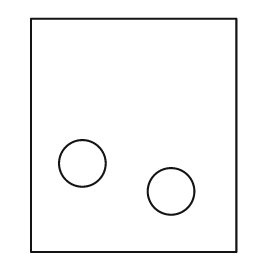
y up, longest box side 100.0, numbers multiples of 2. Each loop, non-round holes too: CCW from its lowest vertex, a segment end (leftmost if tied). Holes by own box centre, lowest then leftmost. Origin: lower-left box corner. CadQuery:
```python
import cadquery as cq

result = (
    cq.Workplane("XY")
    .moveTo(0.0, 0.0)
    .lineTo(88.0, 0.0)
    .lineTo(88.0, 100.0)
    .lineTo(0.0, 100.0)
    .close()
    .moveTo(60.0, 26.0)
    .circle(10.0)
    .moveTo(22.0, 38.0)
    .circle(10.0)
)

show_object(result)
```